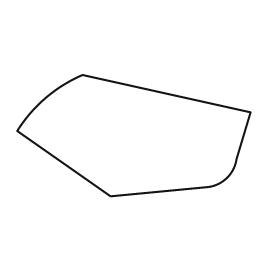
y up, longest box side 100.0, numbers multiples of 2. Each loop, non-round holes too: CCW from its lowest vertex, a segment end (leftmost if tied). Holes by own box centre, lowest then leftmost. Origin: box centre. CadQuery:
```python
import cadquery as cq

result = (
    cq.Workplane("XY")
    .moveTo(-10.0, -26.0)
    .lineTo(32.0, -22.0)
    .threePointArc((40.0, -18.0), (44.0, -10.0))
    .lineTo(50.0, 10.0)
    .lineTo(-22.0, 26.0)
    .threePointArc((-38.0, 16.0), (-50.0, 2.0))
    .close()
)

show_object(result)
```